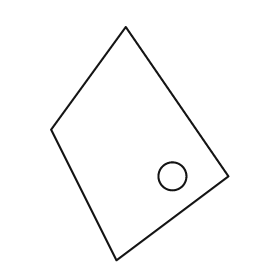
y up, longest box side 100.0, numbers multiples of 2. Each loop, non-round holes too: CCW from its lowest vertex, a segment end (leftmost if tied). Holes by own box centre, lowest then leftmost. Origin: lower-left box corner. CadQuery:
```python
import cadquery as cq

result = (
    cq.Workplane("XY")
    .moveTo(28.0, 0.0)
    .lineTo(76.0, 36.0)
    .lineTo(32.0, 100.0)
    .lineTo(0.0, 56.0)
    .close()
    .moveTo(52.0, 36.0)
    .circle(6.0)
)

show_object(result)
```